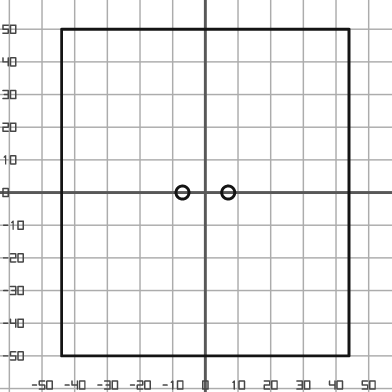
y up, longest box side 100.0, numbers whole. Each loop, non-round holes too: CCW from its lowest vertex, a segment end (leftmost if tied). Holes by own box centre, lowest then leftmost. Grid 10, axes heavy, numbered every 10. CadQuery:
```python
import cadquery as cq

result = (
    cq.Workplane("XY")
    .moveTo(-44.0, -50.0)
    .lineTo(44.0, -50.0)
    .lineTo(44.0, 50.0)
    .lineTo(-44.0, 50.0)
    .close()
    .moveTo(-7.0, 0.0)
    .circle(2.0)
    .moveTo(7.0, 0.0)
    .circle(2.0)
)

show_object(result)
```